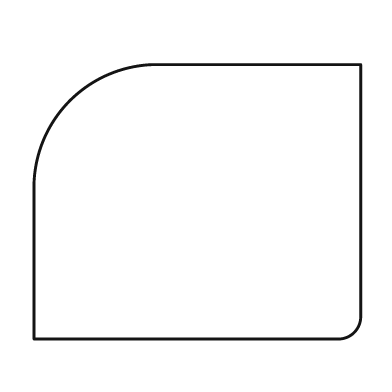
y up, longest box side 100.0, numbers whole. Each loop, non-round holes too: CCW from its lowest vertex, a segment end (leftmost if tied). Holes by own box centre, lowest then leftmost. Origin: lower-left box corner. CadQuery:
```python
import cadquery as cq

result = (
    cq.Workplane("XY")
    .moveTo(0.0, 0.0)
    .lineTo(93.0, 0.0)
    .threePointArc((98.0, 2.0), (100.0, 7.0))
    .lineTo(100.0, 84.0)
    .lineTo(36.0, 84.0)
    .threePointArc((11.0, 73.0), (0.0, 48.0))
    .close()
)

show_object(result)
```